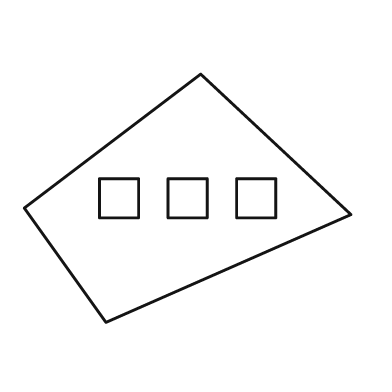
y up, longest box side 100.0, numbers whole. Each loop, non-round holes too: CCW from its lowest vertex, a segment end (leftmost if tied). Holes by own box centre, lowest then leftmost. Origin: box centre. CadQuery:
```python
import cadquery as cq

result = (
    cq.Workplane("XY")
    .moveTo(-25.0, -38.0)
    .lineTo(50.0, -5.0)
    .lineTo(4.0, 38.0)
    .lineTo(-50.0, -3.0)
    .close()
    .moveTo(-27.0, -6.0)
    .lineTo(-15.0, -6.0)
    .lineTo(-15.0, 6.0)
    .lineTo(-27.0, 6.0)
    .close()
    .moveTo(-6.0, -6.0)
    .lineTo(6.0, -6.0)
    .lineTo(6.0, 6.0)
    .lineTo(-6.0, 6.0)
    .close()
    .moveTo(15.0, -6.0)
    .lineTo(27.0, -6.0)
    .lineTo(27.0, 6.0)
    .lineTo(15.0, 6.0)
    .close()
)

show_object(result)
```